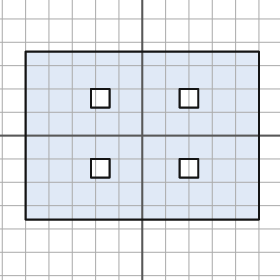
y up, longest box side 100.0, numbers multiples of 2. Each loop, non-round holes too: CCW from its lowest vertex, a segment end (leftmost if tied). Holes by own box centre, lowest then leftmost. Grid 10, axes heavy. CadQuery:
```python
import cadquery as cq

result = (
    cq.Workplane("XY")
    .moveTo(-50.0, -36.0)
    .lineTo(50.0, -36.0)
    .lineTo(50.0, 36.0)
    .lineTo(-50.0, 36.0)
    .close()
    .moveTo(-22.0, -18.0)
    .lineTo(-14.0, -18.0)
    .lineTo(-14.0, -10.0)
    .lineTo(-22.0, -10.0)
    .close()
    .moveTo(16.0, -18.0)
    .lineTo(24.0, -18.0)
    .lineTo(24.0, -10.0)
    .lineTo(16.0, -10.0)
    .close()
    .moveTo(-22.0, 12.0)
    .lineTo(-14.0, 12.0)
    .lineTo(-14.0, 20.0)
    .lineTo(-22.0, 20.0)
    .close()
    .moveTo(16.0, 12.0)
    .lineTo(24.0, 12.0)
    .lineTo(24.0, 20.0)
    .lineTo(16.0, 20.0)
    .close()
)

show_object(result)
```